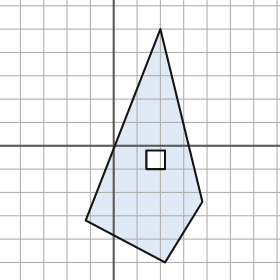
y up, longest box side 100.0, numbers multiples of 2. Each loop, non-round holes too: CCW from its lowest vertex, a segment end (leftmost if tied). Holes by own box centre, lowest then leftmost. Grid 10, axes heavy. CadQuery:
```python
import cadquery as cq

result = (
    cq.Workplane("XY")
    .moveTo(22.0, -50.0)
    .lineTo(38.0, -24.0)
    .lineTo(20.0, 50.0)
    .lineTo(-12.0, -32.0)
    .close()
    .moveTo(14.0, -10.0)
    .lineTo(22.0, -10.0)
    .lineTo(22.0, -2.0)
    .lineTo(14.0, -2.0)
    .close()
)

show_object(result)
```